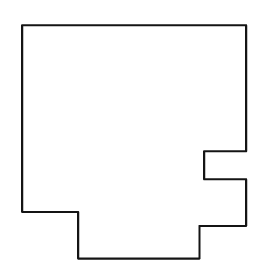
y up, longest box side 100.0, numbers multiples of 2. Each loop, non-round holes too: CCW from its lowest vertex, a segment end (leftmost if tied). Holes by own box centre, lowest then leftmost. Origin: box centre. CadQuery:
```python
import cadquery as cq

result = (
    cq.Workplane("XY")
    .moveTo(-24.0, -50.0)
    .lineTo(28.0, -50.0)
    .lineTo(28.0, -36.0)
    .lineTo(48.0, -36.0)
    .lineTo(48.0, -16.0)
    .lineTo(30.0, -16.0)
    .lineTo(30.0, -4.0)
    .lineTo(48.0, -4.0)
    .lineTo(48.0, 50.0)
    .lineTo(-48.0, 50.0)
    .lineTo(-48.0, -30.0)
    .lineTo(-24.0, -30.0)
    .close()
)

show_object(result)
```